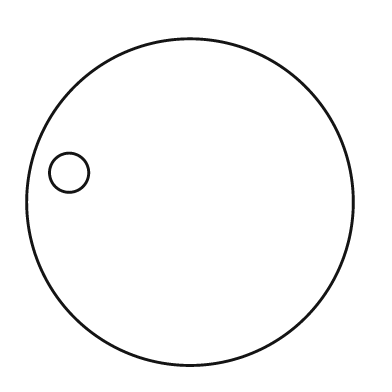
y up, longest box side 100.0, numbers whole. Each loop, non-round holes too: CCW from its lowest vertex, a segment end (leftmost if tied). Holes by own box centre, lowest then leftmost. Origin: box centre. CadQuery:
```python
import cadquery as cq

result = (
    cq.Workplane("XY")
    .moveTo(0.0, 0.0)
    .circle(50.0)
    .moveTo(-37.0, 9.0)
    .circle(6.0)
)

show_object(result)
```